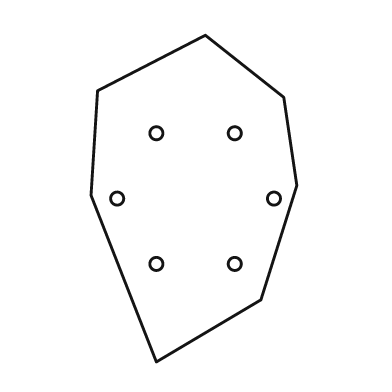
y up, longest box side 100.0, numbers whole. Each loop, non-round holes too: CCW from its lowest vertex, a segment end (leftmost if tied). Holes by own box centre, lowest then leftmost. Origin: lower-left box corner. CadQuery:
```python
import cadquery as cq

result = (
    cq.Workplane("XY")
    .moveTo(20.0, 0.0)
    .lineTo(52.0, 19.0)
    .lineTo(63.0, 54.0)
    .lineTo(59.0, 81.0)
    .lineTo(35.0, 100.0)
    .lineTo(2.0, 83.0)
    .lineTo(0.0, 51.0)
    .close()
    .moveTo(20.0, 30.0)
    .circle(2.0)
    .moveTo(44.0, 30.0)
    .circle(2.0)
    .moveTo(8.0, 50.0)
    .circle(2.0)
    .moveTo(56.0, 50.0)
    .circle(2.0)
    .moveTo(20.0, 70.0)
    .circle(2.0)
    .moveTo(44.0, 70.0)
    .circle(2.0)
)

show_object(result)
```